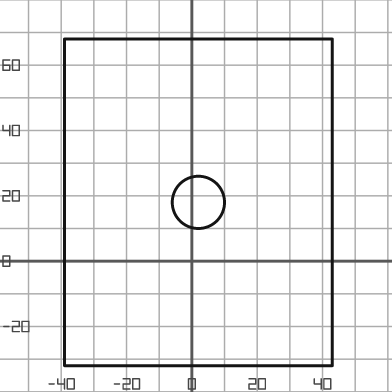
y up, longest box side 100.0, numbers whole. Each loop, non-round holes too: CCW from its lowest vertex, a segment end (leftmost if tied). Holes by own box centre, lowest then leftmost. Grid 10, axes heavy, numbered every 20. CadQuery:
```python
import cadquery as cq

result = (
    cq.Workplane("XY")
    .moveTo(-39.0, -32.0)
    .lineTo(43.0, -32.0)
    .lineTo(43.0, 68.0)
    .lineTo(-39.0, 68.0)
    .close()
    .moveTo(2.0, 18.0)
    .circle(8.0)
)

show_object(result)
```